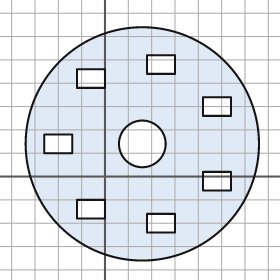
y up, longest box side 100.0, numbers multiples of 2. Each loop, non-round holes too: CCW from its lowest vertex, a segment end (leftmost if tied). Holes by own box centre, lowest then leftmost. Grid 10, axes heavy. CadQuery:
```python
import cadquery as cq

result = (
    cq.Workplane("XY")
    .moveTo(16.0, 14.0)
    .circle(50.0)
    .moveTo(18.0, -24.0)
    .lineTo(30.0, -24.0)
    .lineTo(30.0, -16.0)
    .lineTo(18.0, -16.0)
    .close()
    .moveTo(-12.0, -18.0)
    .lineTo(0.0, -18.0)
    .lineTo(0.0, -10.0)
    .lineTo(-12.0, -10.0)
    .close()
    .moveTo(42.0, -6.0)
    .lineTo(54.0, -6.0)
    .lineTo(54.0, 2.0)
    .lineTo(42.0, 2.0)
    .close()
    .moveTo(-26.0, 10.0)
    .lineTo(-14.0, 10.0)
    .lineTo(-14.0, 18.0)
    .lineTo(-26.0, 18.0)
    .close()
    .moveTo(16.0, 14.0)
    .circle(10.0)
    .moveTo(42.0, 26.0)
    .lineTo(54.0, 26.0)
    .lineTo(54.0, 34.0)
    .lineTo(42.0, 34.0)
    .close()
    .moveTo(-12.0, 38.0)
    .lineTo(0.0, 38.0)
    .lineTo(0.0, 46.0)
    .lineTo(-12.0, 46.0)
    .close()
    .moveTo(18.0, 44.0)
    .lineTo(30.0, 44.0)
    .lineTo(30.0, 52.0)
    .lineTo(18.0, 52.0)
    .close()
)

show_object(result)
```